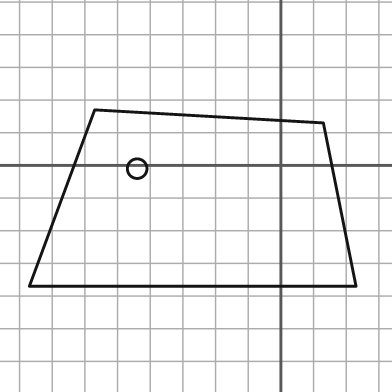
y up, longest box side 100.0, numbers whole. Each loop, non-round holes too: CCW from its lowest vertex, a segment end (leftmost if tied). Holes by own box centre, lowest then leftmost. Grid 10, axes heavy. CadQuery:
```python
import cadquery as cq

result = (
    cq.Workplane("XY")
    .moveTo(-77.0, -37.0)
    .lineTo(23.0, -37.0)
    .lineTo(13.0, 13.0)
    .lineTo(-57.0, 17.0)
    .close()
    .moveTo(-44.0, -1.0)
    .circle(3.0)
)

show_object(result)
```